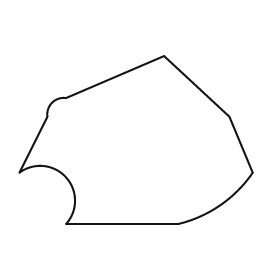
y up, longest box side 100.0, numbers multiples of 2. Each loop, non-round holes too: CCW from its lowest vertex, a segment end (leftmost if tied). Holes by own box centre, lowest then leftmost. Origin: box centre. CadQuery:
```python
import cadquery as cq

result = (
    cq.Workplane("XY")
    .moveTo(-30.0, -36.0)
    .lineTo(18.0, -36.0)
    .threePointArc((36.0, -28.0), (50.0, -14.0))
    .lineTo(40.0, 10.0)
    .lineTo(12.0, 36.0)
    .lineTo(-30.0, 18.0)
    .threePointArc((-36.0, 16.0), (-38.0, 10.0))
    .lineTo(-50.0, -14.0)
    .threePointArc((-30.0, -16.0), (-30.0, -36.0))
    .close()
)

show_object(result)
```